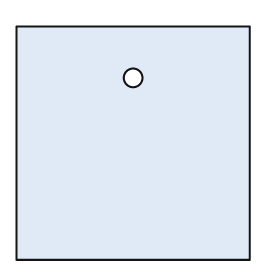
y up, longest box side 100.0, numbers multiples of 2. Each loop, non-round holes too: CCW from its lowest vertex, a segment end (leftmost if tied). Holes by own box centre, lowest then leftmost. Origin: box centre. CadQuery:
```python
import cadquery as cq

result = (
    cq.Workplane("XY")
    .moveTo(-50.0, -50.0)
    .lineTo(50.0, -50.0)
    .lineTo(50.0, 50.0)
    .lineTo(-50.0, 50.0)
    .close()
    .moveTo(0.0, 28.0)
    .circle(4.0)
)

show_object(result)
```